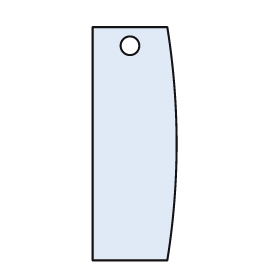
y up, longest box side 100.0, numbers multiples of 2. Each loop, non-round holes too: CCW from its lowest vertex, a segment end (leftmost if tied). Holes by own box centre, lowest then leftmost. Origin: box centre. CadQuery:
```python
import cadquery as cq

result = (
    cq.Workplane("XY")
    .moveTo(-18.0, -50.0)
    .lineTo(14.0, -50.0)
    .threePointArc((18.0, 0.0), (14.0, 50.0))
    .lineTo(-18.0, 50.0)
    .close()
    .moveTo(-2.0, 42.0)
    .circle(4.0)
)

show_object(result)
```